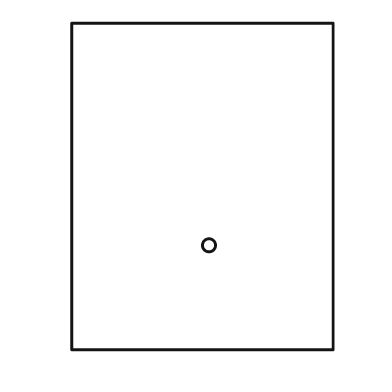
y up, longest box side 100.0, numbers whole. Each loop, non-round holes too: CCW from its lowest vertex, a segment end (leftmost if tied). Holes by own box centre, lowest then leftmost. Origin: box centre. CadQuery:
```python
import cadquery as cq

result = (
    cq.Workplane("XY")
    .moveTo(-40.0, -50.0)
    .lineTo(40.0, -50.0)
    .lineTo(40.0, 50.0)
    .lineTo(-40.0, 50.0)
    .close()
    .moveTo(2.0, -18.0)
    .circle(2.0)
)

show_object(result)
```